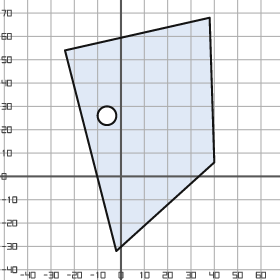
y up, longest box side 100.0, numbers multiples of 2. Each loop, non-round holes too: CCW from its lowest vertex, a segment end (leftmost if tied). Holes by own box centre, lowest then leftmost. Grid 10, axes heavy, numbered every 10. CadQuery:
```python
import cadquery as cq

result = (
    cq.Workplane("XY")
    .moveTo(-2.0, -32.0)
    .lineTo(40.0, 6.0)
    .lineTo(38.0, 68.0)
    .lineTo(-24.0, 54.0)
    .close()
    .moveTo(-6.0, 26.0)
    .circle(4.0)
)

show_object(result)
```